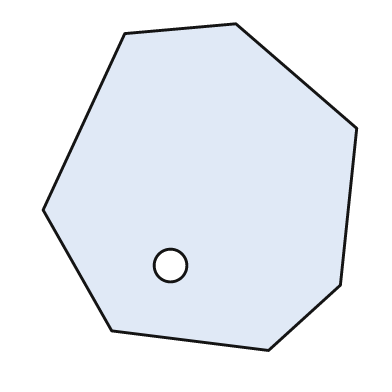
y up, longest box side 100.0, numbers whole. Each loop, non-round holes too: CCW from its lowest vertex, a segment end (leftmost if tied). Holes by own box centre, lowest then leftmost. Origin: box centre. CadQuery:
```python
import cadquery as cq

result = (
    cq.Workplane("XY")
    .moveTo(21.0, -50.0)
    .lineTo(43.0, -30.0)
    .lineTo(48.0, 18.0)
    .lineTo(11.0, 50.0)
    .lineTo(-23.0, 47.0)
    .lineTo(-48.0, -7.0)
    .lineTo(-27.0, -44.0)
    .close()
    .moveTo(-9.0, -24.0)
    .circle(5.0)
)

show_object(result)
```